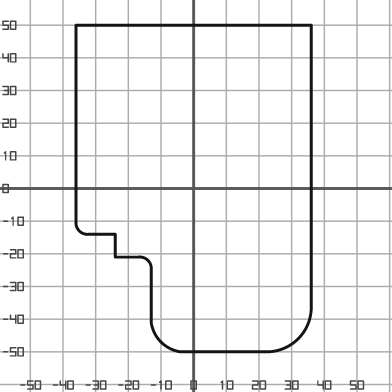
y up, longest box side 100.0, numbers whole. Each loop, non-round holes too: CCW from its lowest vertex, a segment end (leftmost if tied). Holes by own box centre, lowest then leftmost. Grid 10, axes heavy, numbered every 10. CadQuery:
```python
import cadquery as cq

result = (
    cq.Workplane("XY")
    .moveTo(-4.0, -50.0)
    .lineTo(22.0, -50.0)
    .threePointArc((32.0, -46.0), (36.0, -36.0))
    .lineTo(36.0, 50.0)
    .lineTo(-36.0, 50.0)
    .lineTo(-36.0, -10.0)
    .threePointArc((-35.0, -13.0), (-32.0, -14.0))
    .lineTo(-24.0, -14.0)
    .lineTo(-24.0, -21.0)
    .lineTo(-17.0, -21.0)
    .threePointArc((-14.0, -22.0), (-13.0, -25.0))
    .lineTo(-13.0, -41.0)
    .threePointArc((-10.0, -47.0), (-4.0, -50.0))
    .close()
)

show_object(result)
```